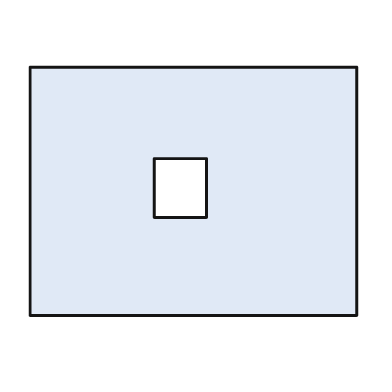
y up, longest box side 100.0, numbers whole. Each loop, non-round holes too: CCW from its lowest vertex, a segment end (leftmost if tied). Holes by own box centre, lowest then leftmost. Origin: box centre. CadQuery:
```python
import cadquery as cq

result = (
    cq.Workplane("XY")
    .moveTo(-50.0, -38.0)
    .lineTo(50.0, -38.0)
    .lineTo(50.0, 38.0)
    .lineTo(-50.0, 38.0)
    .close()
    .moveTo(-12.0, -8.0)
    .lineTo(4.0, -8.0)
    .lineTo(4.0, 10.0)
    .lineTo(-12.0, 10.0)
    .close()
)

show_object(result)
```